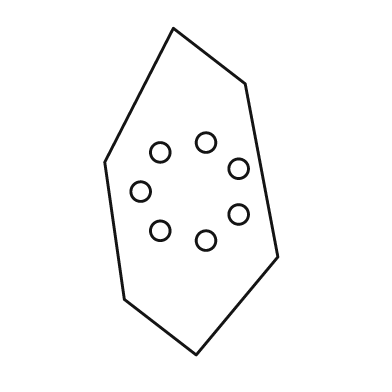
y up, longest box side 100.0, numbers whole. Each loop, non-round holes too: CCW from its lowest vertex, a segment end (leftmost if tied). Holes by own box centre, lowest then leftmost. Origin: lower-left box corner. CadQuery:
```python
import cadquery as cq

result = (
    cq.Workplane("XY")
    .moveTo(28.0, 0.0)
    .lineTo(53.0, 30.0)
    .lineTo(43.0, 83.0)
    .lineTo(21.0, 100.0)
    .lineTo(0.0, 59.0)
    .lineTo(6.0, 17.0)
    .close()
    .moveTo(31.0, 35.0)
    .circle(3.0)
    .moveTo(17.0, 38.0)
    .circle(3.0)
    .moveTo(41.0, 43.0)
    .circle(3.0)
    .moveTo(11.0, 50.0)
    .circle(3.0)
    .moveTo(41.0, 57.0)
    .circle(3.0)
    .moveTo(17.0, 62.0)
    .circle(3.0)
    .moveTo(31.0, 65.0)
    .circle(3.0)
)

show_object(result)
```